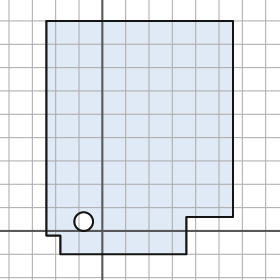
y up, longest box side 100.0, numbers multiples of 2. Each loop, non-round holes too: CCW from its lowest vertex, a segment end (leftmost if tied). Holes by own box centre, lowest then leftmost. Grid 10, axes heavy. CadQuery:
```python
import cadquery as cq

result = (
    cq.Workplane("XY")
    .moveTo(-18.0, -10.0)
    .lineTo(36.0, -10.0)
    .lineTo(36.0, 6.0)
    .lineTo(56.0, 6.0)
    .lineTo(56.0, 90.0)
    .lineTo(-24.0, 90.0)
    .lineTo(-24.0, -2.0)
    .lineTo(-18.0, -2.0)
    .close()
    .moveTo(-8.0, 4.0)
    .circle(4.0)
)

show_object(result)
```